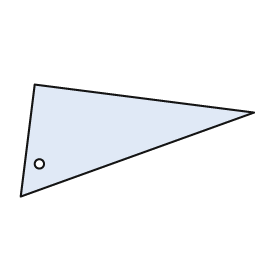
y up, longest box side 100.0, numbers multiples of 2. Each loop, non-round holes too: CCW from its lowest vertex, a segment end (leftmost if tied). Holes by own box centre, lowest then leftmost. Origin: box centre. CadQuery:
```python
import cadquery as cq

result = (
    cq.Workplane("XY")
    .moveTo(-50.0, -24.0)
    .lineTo(50.0, 12.0)
    .lineTo(-44.0, 24.0)
    .close()
    .moveTo(-42.0, -10.0)
    .circle(2.0)
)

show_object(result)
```